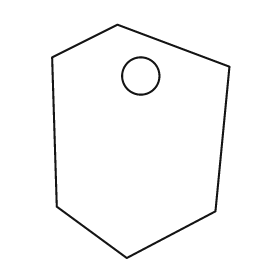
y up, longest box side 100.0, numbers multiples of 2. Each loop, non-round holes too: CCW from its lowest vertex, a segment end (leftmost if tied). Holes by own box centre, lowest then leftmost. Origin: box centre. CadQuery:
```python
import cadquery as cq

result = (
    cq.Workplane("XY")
    .moveTo(-6.0, -50.0)
    .lineTo(32.0, -30.0)
    .lineTo(38.0, 32.0)
    .lineTo(-10.0, 50.0)
    .lineTo(-38.0, 36.0)
    .lineTo(-36.0, -28.0)
    .close()
    .moveTo(0.0, 28.0)
    .circle(8.0)
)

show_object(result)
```